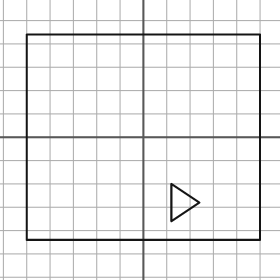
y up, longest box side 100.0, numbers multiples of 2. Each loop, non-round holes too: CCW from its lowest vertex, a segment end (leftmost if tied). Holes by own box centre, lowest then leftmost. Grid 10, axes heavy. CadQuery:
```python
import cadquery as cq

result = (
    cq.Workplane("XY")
    .moveTo(-50.0, -44.0)
    .lineTo(50.0, -44.0)
    .lineTo(50.0, 44.0)
    .lineTo(-50.0, 44.0)
    .close()
    .moveTo(12.0, -36.0)
    .lineTo(24.0, -28.0)
    .lineTo(12.0, -20.0)
    .close()
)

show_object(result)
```